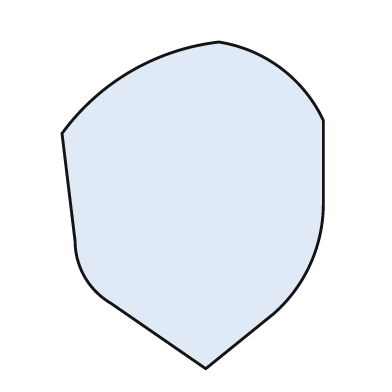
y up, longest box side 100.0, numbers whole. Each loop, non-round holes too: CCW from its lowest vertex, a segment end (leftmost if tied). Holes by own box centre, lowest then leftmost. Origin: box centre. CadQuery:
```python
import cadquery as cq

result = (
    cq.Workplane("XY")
    .moveTo(4.0, -50.0)
    .lineTo(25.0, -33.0)
    .threePointArc((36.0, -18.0), (40.0, 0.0))
    .lineTo(40.0, 26.0)
    .threePointArc((27.0, 42.0), (8.0, 50.0))
    .threePointArc((-19.0, 41.0), (-40.0, 22.0))
    .lineTo(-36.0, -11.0)
    .threePointArc((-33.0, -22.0), (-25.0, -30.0))
    .close()
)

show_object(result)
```